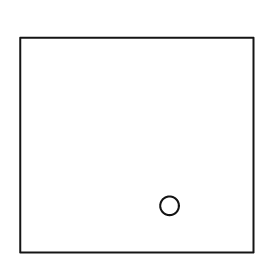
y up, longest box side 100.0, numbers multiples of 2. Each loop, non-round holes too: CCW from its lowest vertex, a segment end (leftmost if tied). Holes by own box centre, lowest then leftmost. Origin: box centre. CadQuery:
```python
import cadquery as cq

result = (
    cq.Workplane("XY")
    .moveTo(-50.0, -46.0)
    .lineTo(50.0, -46.0)
    .lineTo(50.0, 46.0)
    .lineTo(-50.0, 46.0)
    .close()
    .moveTo(14.0, -26.0)
    .circle(4.0)
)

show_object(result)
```